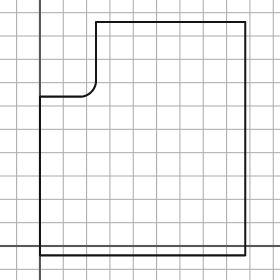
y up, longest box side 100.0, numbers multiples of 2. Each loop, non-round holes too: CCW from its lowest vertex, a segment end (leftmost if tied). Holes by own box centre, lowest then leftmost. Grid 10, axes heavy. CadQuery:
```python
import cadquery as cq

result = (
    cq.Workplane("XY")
    .moveTo(0.0, -4.0)
    .lineTo(88.0, -4.0)
    .lineTo(88.0, 96.0)
    .lineTo(24.0, 96.0)
    .lineTo(24.0, 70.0)
    .threePointArc((22.0, 66.0), (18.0, 64.0))
    .lineTo(0.0, 64.0)
    .close()
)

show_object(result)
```